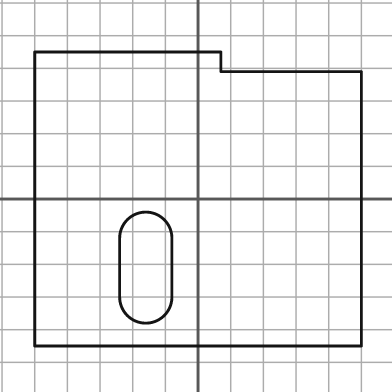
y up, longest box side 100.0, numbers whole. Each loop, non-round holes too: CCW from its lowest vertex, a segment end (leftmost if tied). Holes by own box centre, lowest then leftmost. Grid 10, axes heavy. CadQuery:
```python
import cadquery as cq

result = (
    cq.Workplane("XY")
    .moveTo(-50.0, -45.0)
    .lineTo(50.0, -45.0)
    .lineTo(50.0, 39.0)
    .lineTo(7.0, 39.0)
    .lineTo(7.0, 45.0)
    .lineTo(-50.0, 45.0)
    .close()
    .moveTo(-24.0, -30.0)
    .threePointArc((-16.0, -38.0), (-8.0, -30.0))
    .lineTo(-8.0, -12.0)
    .threePointArc((-16.0, -4.0), (-24.0, -12.0))
    .close()
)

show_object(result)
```